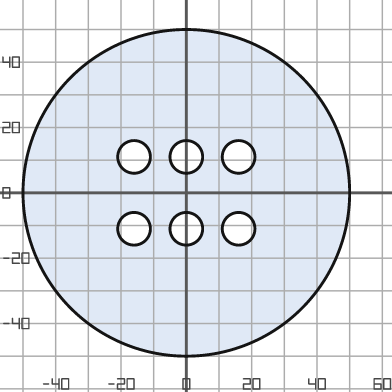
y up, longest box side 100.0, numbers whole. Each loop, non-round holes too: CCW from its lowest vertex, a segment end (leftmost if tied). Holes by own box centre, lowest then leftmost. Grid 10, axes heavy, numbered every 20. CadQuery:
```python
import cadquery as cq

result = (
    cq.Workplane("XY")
    .moveTo(0.0, 0.0)
    .circle(50.0)
    .moveTo(-16.0, -11.0)
    .circle(5.0)
    .moveTo(0.0, -11.0)
    .circle(5.0)
    .moveTo(16.0, -11.0)
    .circle(5.0)
    .moveTo(-16.0, 11.0)
    .circle(5.0)
    .moveTo(0.0, 11.0)
    .circle(5.0)
    .moveTo(16.0, 11.0)
    .circle(5.0)
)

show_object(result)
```